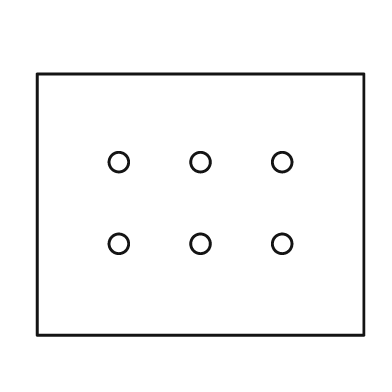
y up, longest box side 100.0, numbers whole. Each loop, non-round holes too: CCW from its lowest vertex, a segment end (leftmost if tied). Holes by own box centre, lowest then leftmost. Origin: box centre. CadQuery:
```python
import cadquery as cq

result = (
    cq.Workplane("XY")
    .moveTo(-50.0, -40.0)
    .lineTo(50.0, -40.0)
    .lineTo(50.0, 40.0)
    .lineTo(-50.0, 40.0)
    .close()
    .moveTo(-25.0, -12.0)
    .circle(3.0)
    .moveTo(0.0, -12.0)
    .circle(3.0)
    .moveTo(25.0, -12.0)
    .circle(3.0)
    .moveTo(-25.0, 13.0)
    .circle(3.0)
    .moveTo(0.0, 13.0)
    .circle(3.0)
    .moveTo(25.0, 13.0)
    .circle(3.0)
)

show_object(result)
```